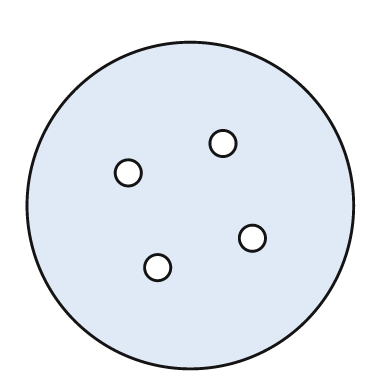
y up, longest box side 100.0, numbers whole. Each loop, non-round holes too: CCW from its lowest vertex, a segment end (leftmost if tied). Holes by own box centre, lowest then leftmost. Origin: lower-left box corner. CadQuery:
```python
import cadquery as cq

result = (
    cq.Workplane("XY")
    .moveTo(50.0, 50.0)
    .circle(50.0)
    .moveTo(40.0, 31.0)
    .circle(4.0)
    .moveTo(69.0, 40.0)
    .circle(4.0)
    .moveTo(31.0, 60.0)
    .circle(4.0)
    .moveTo(60.0, 69.0)
    .circle(4.0)
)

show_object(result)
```